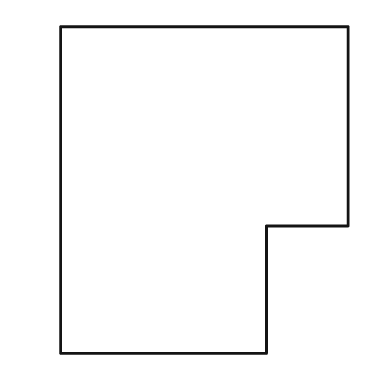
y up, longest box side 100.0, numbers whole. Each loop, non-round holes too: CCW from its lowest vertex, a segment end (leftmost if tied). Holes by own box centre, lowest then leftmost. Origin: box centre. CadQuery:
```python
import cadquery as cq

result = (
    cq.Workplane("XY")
    .moveTo(-44.0, -50.0)
    .lineTo(19.0, -50.0)
    .lineTo(19.0, -11.0)
    .lineTo(44.0, -11.0)
    .lineTo(44.0, 50.0)
    .lineTo(-44.0, 50.0)
    .close()
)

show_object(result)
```